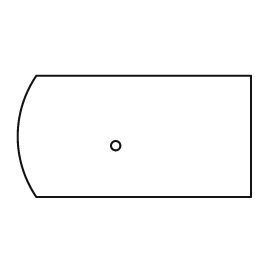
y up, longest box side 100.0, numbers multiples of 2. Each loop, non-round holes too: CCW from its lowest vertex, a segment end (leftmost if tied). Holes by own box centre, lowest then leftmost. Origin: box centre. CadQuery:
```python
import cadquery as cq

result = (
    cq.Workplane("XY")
    .moveTo(-42.0, -26.0)
    .lineTo(50.0, -26.0)
    .lineTo(50.0, 26.0)
    .lineTo(-42.0, 26.0)
    .threePointArc((-50.0, 0.0), (-42.0, -26.0))
    .close()
    .moveTo(-8.0, -4.0)
    .circle(2.0)
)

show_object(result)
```